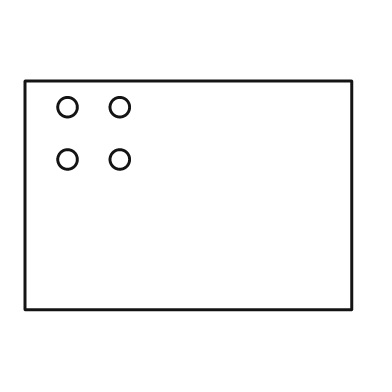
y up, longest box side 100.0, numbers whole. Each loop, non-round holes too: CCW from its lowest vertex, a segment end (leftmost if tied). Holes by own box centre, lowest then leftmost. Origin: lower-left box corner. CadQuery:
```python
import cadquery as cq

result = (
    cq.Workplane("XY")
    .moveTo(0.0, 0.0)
    .lineTo(100.0, 0.0)
    .lineTo(100.0, 70.0)
    .lineTo(0.0, 70.0)
    .close()
    .moveTo(13.0, 46.0)
    .circle(3.0)
    .moveTo(29.0, 46.0)
    .circle(3.0)
    .moveTo(13.0, 62.0)
    .circle(3.0)
    .moveTo(29.0, 62.0)
    .circle(3.0)
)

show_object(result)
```